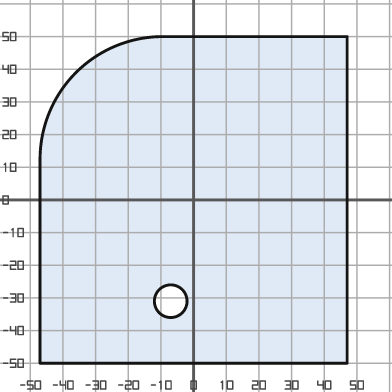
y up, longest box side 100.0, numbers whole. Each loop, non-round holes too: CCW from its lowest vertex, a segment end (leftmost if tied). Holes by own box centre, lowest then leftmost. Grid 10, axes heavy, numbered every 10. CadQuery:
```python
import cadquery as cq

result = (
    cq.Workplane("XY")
    .moveTo(-47.0, -50.0)
    .lineTo(47.0, -50.0)
    .lineTo(47.0, 50.0)
    .lineTo(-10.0, 50.0)
    .threePointArc((-36.0, 39.0), (-47.0, 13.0))
    .close()
    .moveTo(-7.0, -31.0)
    .circle(5.0)
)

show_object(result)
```